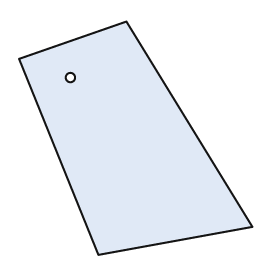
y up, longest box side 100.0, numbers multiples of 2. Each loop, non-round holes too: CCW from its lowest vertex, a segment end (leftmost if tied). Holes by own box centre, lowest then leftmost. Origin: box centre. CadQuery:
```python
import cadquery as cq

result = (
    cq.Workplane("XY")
    .moveTo(-16.0, -50.0)
    .lineTo(50.0, -38.0)
    .lineTo(-4.0, 50.0)
    .lineTo(-50.0, 34.0)
    .close()
    .moveTo(-28.0, 26.0)
    .circle(2.0)
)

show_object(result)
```